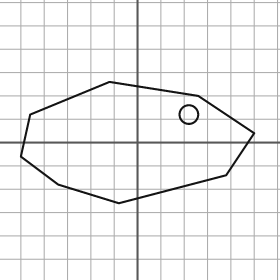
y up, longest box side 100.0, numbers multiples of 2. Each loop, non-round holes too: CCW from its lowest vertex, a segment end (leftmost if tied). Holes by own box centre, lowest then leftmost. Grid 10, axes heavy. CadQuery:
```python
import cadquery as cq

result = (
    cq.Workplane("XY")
    .moveTo(-8.0, -26.0)
    .lineTo(38.0, -14.0)
    .lineTo(50.0, 4.0)
    .lineTo(26.0, 20.0)
    .lineTo(-12.0, 26.0)
    .lineTo(-46.0, 12.0)
    .lineTo(-50.0, -6.0)
    .lineTo(-34.0, -18.0)
    .close()
    .moveTo(22.0, 12.0)
    .circle(4.0)
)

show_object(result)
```